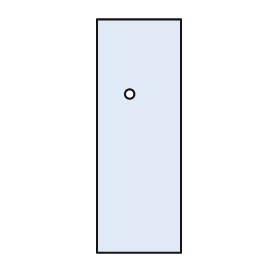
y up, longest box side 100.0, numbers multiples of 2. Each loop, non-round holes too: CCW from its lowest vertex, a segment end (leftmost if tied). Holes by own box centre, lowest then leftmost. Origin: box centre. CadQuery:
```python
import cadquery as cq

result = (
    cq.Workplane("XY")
    .moveTo(-18.0, -50.0)
    .lineTo(18.0, -50.0)
    .lineTo(18.0, 50.0)
    .lineTo(-18.0, 50.0)
    .close()
    .moveTo(-4.0, 18.0)
    .circle(2.0)
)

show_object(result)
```